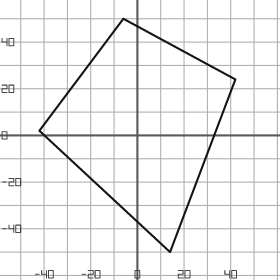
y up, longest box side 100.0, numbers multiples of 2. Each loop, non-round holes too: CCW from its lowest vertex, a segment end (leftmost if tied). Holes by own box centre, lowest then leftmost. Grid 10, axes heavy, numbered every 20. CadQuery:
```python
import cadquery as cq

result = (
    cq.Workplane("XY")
    .moveTo(14.0, -50.0)
    .lineTo(42.0, 24.0)
    .lineTo(-6.0, 50.0)
    .lineTo(-42.0, 2.0)
    .close()
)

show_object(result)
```